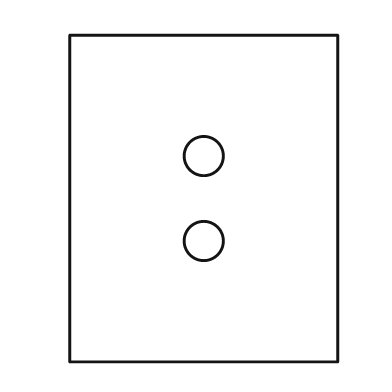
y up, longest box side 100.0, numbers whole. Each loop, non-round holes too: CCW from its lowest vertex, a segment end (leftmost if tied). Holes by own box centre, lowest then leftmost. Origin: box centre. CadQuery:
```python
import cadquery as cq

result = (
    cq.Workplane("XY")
    .moveTo(-41.0, -50.0)
    .lineTo(41.0, -50.0)
    .lineTo(41.0, 50.0)
    .lineTo(-41.0, 50.0)
    .close()
    .moveTo(0.0, -13.0)
    .circle(6.0)
    .moveTo(0.0, 13.0)
    .circle(6.0)
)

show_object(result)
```